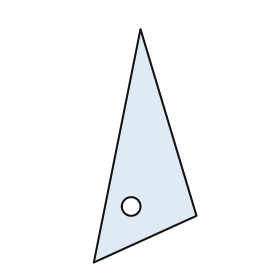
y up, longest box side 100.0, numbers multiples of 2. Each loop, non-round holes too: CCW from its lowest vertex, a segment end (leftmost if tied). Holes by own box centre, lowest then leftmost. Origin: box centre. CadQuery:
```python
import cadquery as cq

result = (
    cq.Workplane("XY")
    .moveTo(-22.0, -50.0)
    .lineTo(22.0, -30.0)
    .lineTo(-2.0, 50.0)
    .close()
    .moveTo(-6.0, -26.0)
    .circle(4.0)
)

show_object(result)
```